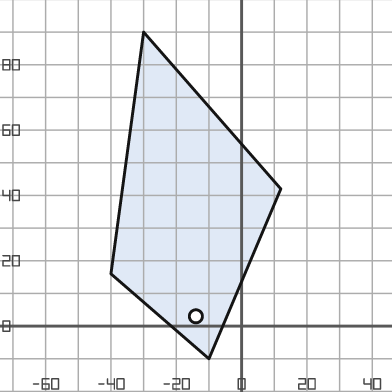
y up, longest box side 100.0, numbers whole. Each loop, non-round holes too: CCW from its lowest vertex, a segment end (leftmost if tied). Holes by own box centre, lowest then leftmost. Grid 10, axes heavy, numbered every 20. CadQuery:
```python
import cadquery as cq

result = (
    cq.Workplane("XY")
    .moveTo(-10.0, -10.0)
    .lineTo(12.0, 42.0)
    .lineTo(-30.0, 90.0)
    .lineTo(-40.0, 16.0)
    .close()
    .moveTo(-14.0, 3.0)
    .circle(2.0)
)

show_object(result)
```